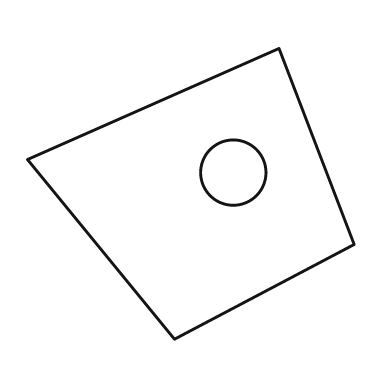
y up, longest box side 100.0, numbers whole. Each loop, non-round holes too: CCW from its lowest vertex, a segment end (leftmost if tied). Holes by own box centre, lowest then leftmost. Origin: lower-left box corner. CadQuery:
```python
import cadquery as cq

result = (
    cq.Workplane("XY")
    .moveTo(45.0, 0.0)
    .lineTo(100.0, 29.0)
    .lineTo(77.0, 89.0)
    .lineTo(0.0, 55.0)
    .close()
    .moveTo(63.0, 51.0)
    .circle(10.0)
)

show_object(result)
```